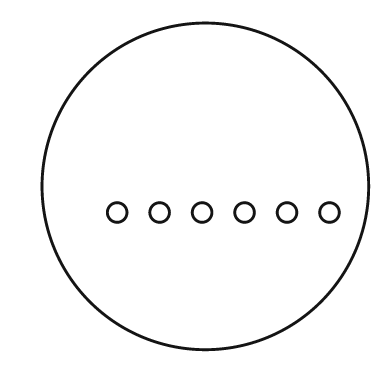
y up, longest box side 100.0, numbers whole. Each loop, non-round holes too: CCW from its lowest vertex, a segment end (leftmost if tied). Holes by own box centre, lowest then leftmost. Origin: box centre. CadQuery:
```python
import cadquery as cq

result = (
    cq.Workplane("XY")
    .moveTo(0.0, 0.0)
    .circle(50.0)
    .moveTo(-27.0, -8.0)
    .circle(3.0)
    .moveTo(-14.0, -8.0)
    .circle(3.0)
    .moveTo(-1.0, -8.0)
    .circle(3.0)
    .moveTo(12.0, -8.0)
    .circle(3.0)
    .moveTo(25.0, -8.0)
    .circle(3.0)
    .moveTo(38.0, -8.0)
    .circle(3.0)
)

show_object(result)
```